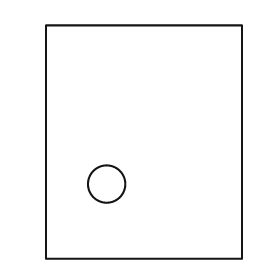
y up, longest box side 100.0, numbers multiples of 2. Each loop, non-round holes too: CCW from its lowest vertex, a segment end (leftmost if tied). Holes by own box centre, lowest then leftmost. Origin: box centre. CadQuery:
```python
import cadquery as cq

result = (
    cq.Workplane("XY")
    .moveTo(-42.0, -50.0)
    .lineTo(42.0, -50.0)
    .lineTo(42.0, 50.0)
    .lineTo(-42.0, 50.0)
    .close()
    .moveTo(-16.0, -18.0)
    .circle(8.0)
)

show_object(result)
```